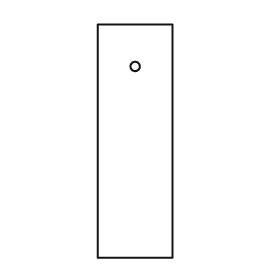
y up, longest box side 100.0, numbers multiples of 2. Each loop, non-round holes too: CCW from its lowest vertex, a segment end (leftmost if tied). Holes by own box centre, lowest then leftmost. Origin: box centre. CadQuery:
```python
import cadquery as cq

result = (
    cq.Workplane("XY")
    .moveTo(-16.0, -50.0)
    .lineTo(16.0, -50.0)
    .lineTo(16.0, 50.0)
    .lineTo(-16.0, 50.0)
    .close()
    .moveTo(0.0, 32.0)
    .circle(2.0)
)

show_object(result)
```